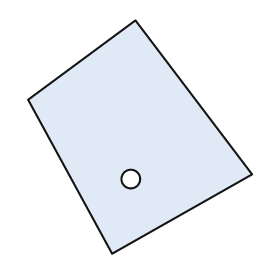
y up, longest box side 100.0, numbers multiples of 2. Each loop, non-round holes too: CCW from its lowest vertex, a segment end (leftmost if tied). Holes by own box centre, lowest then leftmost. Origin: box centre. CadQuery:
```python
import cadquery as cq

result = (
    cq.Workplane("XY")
    .moveTo(-12.0, -50.0)
    .lineTo(48.0, -16.0)
    .lineTo(-2.0, 50.0)
    .lineTo(-48.0, 16.0)
    .close()
    .moveTo(-4.0, -18.0)
    .circle(4.0)
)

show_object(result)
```